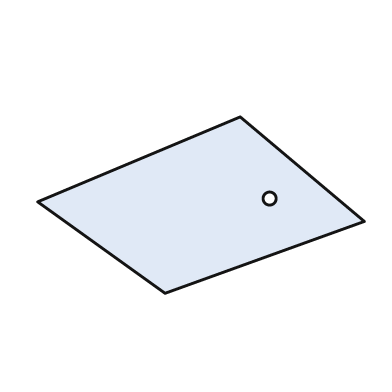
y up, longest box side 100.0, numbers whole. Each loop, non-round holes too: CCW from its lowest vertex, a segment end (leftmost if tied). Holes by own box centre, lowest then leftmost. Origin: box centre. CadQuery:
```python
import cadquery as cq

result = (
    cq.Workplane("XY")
    .moveTo(-11.0, -27.0)
    .lineTo(50.0, -5.0)
    .lineTo(12.0, 27.0)
    .lineTo(-50.0, 1.0)
    .close()
    .moveTo(21.0, 2.0)
    .circle(2.0)
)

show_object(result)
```